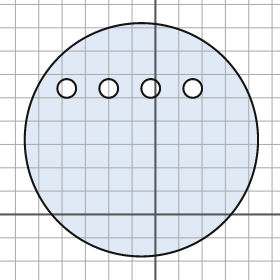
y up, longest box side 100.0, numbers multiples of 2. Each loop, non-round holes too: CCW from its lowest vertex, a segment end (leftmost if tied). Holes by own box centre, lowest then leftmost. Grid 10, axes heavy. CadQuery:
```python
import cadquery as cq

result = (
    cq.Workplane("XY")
    .moveTo(-6.0, 32.0)
    .circle(50.0)
    .moveTo(-38.0, 54.0)
    .circle(4.0)
    .moveTo(-20.0, 54.0)
    .circle(4.0)
    .moveTo(-2.0, 54.0)
    .circle(4.0)
    .moveTo(16.0, 54.0)
    .circle(4.0)
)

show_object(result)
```